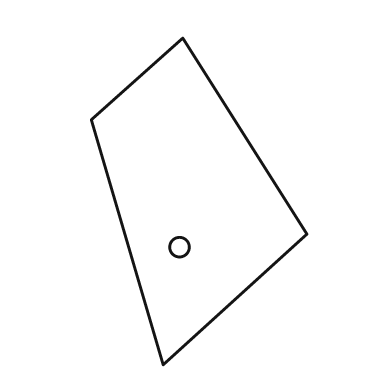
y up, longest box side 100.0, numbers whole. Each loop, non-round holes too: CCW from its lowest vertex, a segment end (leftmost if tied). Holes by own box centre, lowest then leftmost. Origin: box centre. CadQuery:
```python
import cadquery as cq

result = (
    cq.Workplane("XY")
    .moveTo(-11.0, -50.0)
    .lineTo(33.0, -10.0)
    .lineTo(-5.0, 50.0)
    .lineTo(-33.0, 25.0)
    .close()
    .moveTo(-6.0, -14.0)
    .circle(3.0)
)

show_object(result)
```